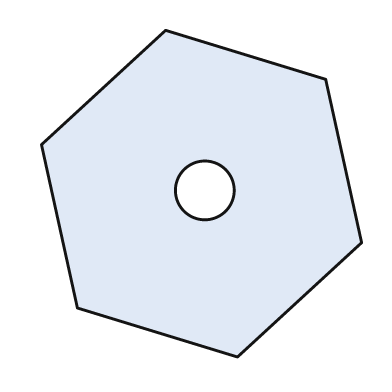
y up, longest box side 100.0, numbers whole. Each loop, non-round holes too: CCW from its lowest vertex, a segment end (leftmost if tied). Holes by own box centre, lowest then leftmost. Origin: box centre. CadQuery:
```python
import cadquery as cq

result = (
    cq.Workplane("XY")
    .moveTo(11.0, -50.0)
    .lineTo(49.0, -15.0)
    .lineTo(38.0, 35.0)
    .lineTo(-11.0, 50.0)
    .lineTo(-49.0, 15.0)
    .lineTo(-38.0, -35.0)
    .close()
    .moveTo(1.0, 1.0)
    .circle(9.0)
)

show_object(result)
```